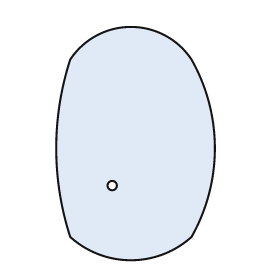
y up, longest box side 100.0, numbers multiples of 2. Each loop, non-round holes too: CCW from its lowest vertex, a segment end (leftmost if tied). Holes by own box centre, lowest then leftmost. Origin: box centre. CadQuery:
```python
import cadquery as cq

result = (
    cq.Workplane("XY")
    .moveTo(-28.0, -40.0)
    .threePointArc((-2.0, -50.0), (24.0, -40.0))
    .threePointArc((34.0, -2.0), (24.0, 36.0))
    .threePointArc((-2.0, 50.0), (-28.0, 36.0))
    .threePointArc((-34.0, -2.0), (-28.0, -40.0))
    .close()
    .moveTo(-10.0, -18.0)
    .circle(2.0)
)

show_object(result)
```